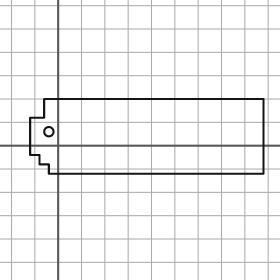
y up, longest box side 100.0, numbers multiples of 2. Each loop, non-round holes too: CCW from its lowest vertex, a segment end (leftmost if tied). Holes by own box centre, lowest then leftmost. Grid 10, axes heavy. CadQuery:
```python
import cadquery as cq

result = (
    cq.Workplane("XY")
    .moveTo(-4.0, -12.0)
    .lineTo(88.0, -12.0)
    .lineTo(88.0, 20.0)
    .lineTo(-6.0, 20.0)
    .lineTo(-6.0, 12.0)
    .lineTo(-12.0, 12.0)
    .lineTo(-12.0, -4.0)
    .lineTo(-8.0, -4.0)
    .lineTo(-8.0, -8.0)
    .lineTo(-4.0, -8.0)
    .close()
    .moveTo(-4.0, 6.0)
    .circle(2.0)
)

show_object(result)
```